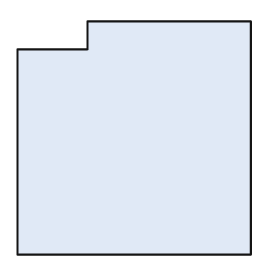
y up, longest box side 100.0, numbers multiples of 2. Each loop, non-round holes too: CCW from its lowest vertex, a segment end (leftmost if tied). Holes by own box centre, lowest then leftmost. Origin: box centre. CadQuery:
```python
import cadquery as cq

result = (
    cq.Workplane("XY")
    .moveTo(-50.0, -50.0)
    .lineTo(50.0, -50.0)
    .lineTo(50.0, 50.0)
    .lineTo(-20.0, 50.0)
    .lineTo(-20.0, 38.0)
    .lineTo(-50.0, 38.0)
    .close()
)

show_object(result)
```